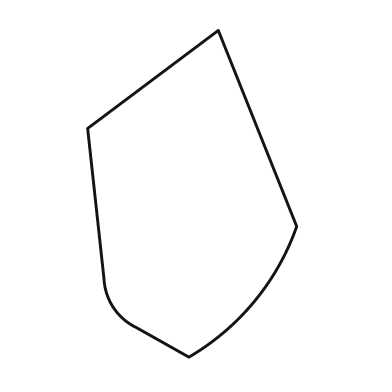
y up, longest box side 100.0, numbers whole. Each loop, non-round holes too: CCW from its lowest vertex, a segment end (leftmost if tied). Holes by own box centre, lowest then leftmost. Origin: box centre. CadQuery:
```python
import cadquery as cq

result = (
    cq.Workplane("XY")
    .moveTo(-1.0, -50.0)
    .threePointArc((19.0, -33.0), (32.0, -10.0))
    .lineTo(8.0, 50.0)
    .lineTo(-32.0, 20.0)
    .lineTo(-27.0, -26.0)
    .threePointArc((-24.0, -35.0), (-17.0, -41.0))
    .close()
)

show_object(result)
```